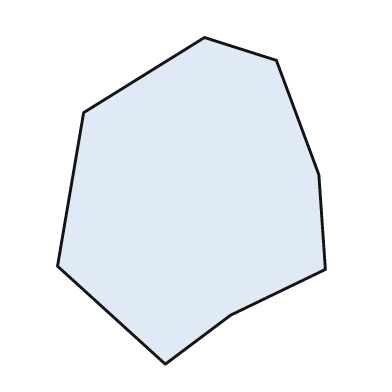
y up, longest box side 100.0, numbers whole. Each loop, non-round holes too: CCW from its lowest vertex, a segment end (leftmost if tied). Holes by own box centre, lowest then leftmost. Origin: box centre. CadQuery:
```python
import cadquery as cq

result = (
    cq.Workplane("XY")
    .moveTo(-8.0, -50.0)
    .lineTo(12.0, -35.0)
    .lineTo(41.0, -21.0)
    .lineTo(39.0, 8.0)
    .lineTo(26.0, 43.0)
    .lineTo(4.0, 50.0)
    .lineTo(-33.0, 27.0)
    .lineTo(-41.0, -20.0)
    .close()
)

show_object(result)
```